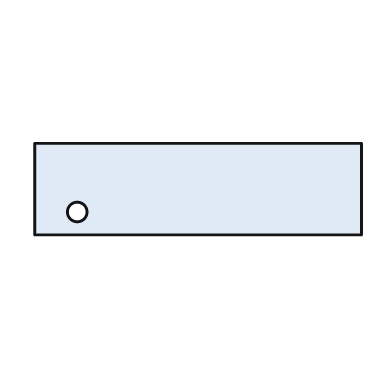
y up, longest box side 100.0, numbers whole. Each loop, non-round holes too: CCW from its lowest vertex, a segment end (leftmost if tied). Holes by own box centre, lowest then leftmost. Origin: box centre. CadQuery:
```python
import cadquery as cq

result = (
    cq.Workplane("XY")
    .moveTo(-50.0, -14.0)
    .lineTo(50.0, -14.0)
    .lineTo(50.0, 14.0)
    .lineTo(-50.0, 14.0)
    .close()
    .moveTo(-37.0, -7.0)
    .circle(3.0)
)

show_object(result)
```